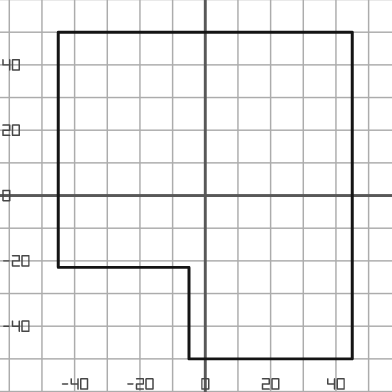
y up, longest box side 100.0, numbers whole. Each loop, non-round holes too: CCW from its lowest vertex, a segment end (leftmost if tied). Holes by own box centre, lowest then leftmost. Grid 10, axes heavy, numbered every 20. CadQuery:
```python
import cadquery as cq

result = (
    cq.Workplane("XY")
    .moveTo(-5.0, -50.0)
    .lineTo(45.0, -50.0)
    .lineTo(45.0, 50.0)
    .lineTo(-45.0, 50.0)
    .lineTo(-45.0, -22.0)
    .lineTo(-5.0, -22.0)
    .close()
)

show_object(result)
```